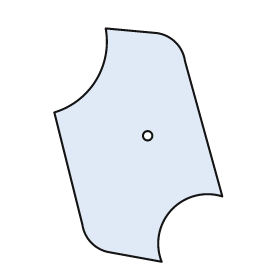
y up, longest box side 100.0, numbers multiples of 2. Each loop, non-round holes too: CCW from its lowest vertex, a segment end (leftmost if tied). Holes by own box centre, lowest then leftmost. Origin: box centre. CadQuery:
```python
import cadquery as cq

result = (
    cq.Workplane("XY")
    .moveTo(10.0, -50.0)
    .threePointArc((14.0, -28.0), (36.0, -22.0))
    .lineTo(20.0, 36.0)
    .threePointArc((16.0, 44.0), (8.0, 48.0))
    .lineTo(-14.0, 50.0)
    .threePointArc((-18.0, 28.0), (-36.0, 14.0))
    .lineTo(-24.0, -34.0)
    .threePointArc((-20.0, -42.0), (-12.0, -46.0))
    .close()
    .moveTo(4.0, 4.0)
    .circle(2.0)
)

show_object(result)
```